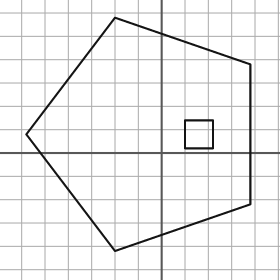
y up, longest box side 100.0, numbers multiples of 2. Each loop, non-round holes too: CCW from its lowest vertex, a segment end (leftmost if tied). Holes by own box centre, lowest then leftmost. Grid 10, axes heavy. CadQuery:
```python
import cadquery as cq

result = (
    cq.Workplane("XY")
    .moveTo(-20.0, -42.0)
    .lineTo(38.0, -22.0)
    .lineTo(38.0, 38.0)
    .lineTo(-20.0, 58.0)
    .lineTo(-58.0, 8.0)
    .close()
    .moveTo(10.0, 2.0)
    .lineTo(22.0, 2.0)
    .lineTo(22.0, 14.0)
    .lineTo(10.0, 14.0)
    .close()
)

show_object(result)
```